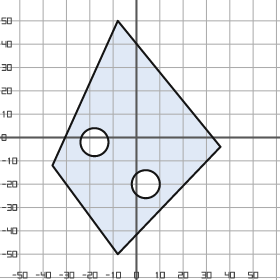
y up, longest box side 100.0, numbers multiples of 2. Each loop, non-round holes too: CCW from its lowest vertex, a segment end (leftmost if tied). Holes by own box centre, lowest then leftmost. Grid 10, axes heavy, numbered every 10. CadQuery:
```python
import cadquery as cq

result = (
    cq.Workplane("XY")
    .moveTo(-8.0, -50.0)
    .lineTo(36.0, -4.0)
    .lineTo(-8.0, 50.0)
    .lineTo(-36.0, -12.0)
    .close()
    .moveTo(4.0, -20.0)
    .circle(6.0)
    .moveTo(-18.0, -2.0)
    .circle(6.0)
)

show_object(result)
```